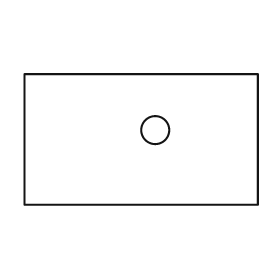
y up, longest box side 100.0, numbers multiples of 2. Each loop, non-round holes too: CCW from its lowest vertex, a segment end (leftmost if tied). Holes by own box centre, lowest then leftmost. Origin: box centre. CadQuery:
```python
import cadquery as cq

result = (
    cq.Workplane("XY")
    .moveTo(-50.0, -28.0)
    .lineTo(50.0, -28.0)
    .lineTo(50.0, 28.0)
    .lineTo(-50.0, 28.0)
    .close()
    .moveTo(6.0, 4.0)
    .circle(6.0)
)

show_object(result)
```